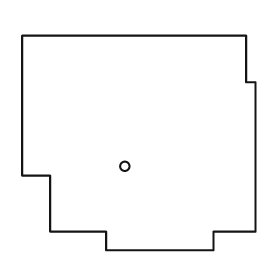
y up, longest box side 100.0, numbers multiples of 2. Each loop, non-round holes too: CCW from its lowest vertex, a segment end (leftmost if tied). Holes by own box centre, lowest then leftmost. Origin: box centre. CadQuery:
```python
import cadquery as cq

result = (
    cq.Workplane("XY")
    .moveTo(-14.0, -46.0)
    .lineTo(32.0, -46.0)
    .lineTo(32.0, -38.0)
    .lineTo(50.0, -38.0)
    .lineTo(50.0, 26.0)
    .lineTo(46.0, 26.0)
    .lineTo(46.0, 46.0)
    .lineTo(-50.0, 46.0)
    .lineTo(-50.0, -14.0)
    .lineTo(-38.0, -14.0)
    .lineTo(-38.0, -38.0)
    .lineTo(-14.0, -38.0)
    .close()
    .moveTo(-6.0, -10.0)
    .circle(2.0)
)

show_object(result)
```